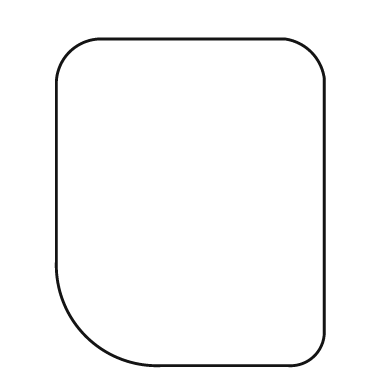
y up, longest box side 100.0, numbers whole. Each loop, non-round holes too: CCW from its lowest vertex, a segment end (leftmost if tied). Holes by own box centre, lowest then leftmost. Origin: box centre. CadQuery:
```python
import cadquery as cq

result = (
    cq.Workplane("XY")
    .moveTo(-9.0, -50.0)
    .lineTo(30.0, -50.0)
    .threePointArc((38.0, -47.0), (41.0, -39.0))
    .lineTo(41.0, 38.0)
    .threePointArc((37.0, 46.0), (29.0, 50.0))
    .lineTo(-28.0, 50.0)
    .threePointArc((-37.0, 46.0), (-41.0, 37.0))
    .lineTo(-41.0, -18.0)
    .threePointArc((-32.0, -41.0), (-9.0, -50.0))
    .close()
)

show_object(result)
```